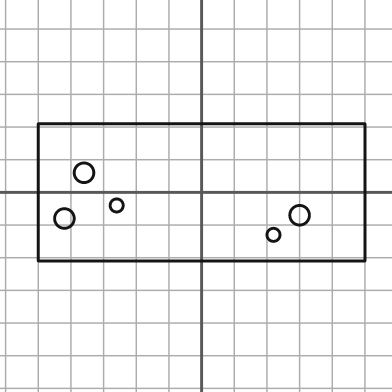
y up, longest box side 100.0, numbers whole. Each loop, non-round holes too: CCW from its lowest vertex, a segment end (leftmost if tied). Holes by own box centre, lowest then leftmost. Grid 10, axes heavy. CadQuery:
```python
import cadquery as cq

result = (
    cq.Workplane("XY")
    .moveTo(-50.0, -21.0)
    .lineTo(50.0, -21.0)
    .lineTo(50.0, 21.0)
    .lineTo(-50.0, 21.0)
    .close()
    .moveTo(22.0, -13.0)
    .circle(2.0)
    .moveTo(-42.0, -8.0)
    .circle(3.0)
    .moveTo(30.0, -7.0)
    .circle(3.0)
    .moveTo(-26.0, -4.0)
    .circle(2.0)
    .moveTo(-36.0, 6.0)
    .circle(3.0)
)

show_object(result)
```